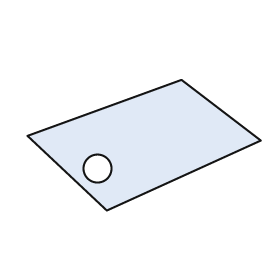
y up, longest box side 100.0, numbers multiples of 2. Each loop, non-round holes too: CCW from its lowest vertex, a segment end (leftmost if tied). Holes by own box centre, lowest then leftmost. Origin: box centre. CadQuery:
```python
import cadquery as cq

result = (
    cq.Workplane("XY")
    .moveTo(-16.0, -28.0)
    .lineTo(50.0, 2.0)
    .lineTo(16.0, 28.0)
    .lineTo(-50.0, 4.0)
    .close()
    .moveTo(-20.0, -10.0)
    .circle(6.0)
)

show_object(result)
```